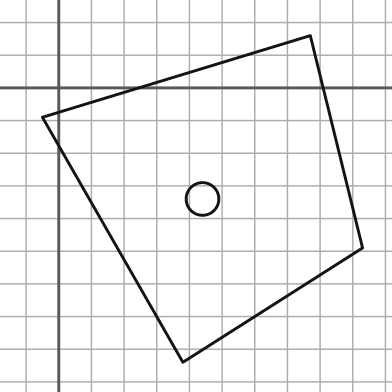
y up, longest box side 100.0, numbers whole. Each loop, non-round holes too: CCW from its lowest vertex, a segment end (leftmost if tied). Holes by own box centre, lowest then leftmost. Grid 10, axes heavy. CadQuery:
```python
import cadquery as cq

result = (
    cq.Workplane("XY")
    .moveTo(38.0, -84.0)
    .lineTo(93.0, -49.0)
    .lineTo(77.0, 16.0)
    .lineTo(-5.0, -9.0)
    .close()
    .moveTo(44.0, -34.0)
    .circle(5.0)
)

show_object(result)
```